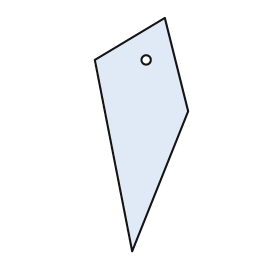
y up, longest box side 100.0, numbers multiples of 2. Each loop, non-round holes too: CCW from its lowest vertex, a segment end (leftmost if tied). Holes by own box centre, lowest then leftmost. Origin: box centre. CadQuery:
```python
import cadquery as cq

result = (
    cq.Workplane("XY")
    .moveTo(-4.0, -50.0)
    .lineTo(20.0, 10.0)
    .lineTo(10.0, 50.0)
    .lineTo(-20.0, 32.0)
    .close()
    .moveTo(2.0, 32.0)
    .circle(2.0)
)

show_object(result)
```